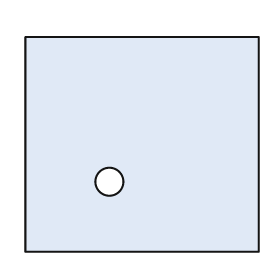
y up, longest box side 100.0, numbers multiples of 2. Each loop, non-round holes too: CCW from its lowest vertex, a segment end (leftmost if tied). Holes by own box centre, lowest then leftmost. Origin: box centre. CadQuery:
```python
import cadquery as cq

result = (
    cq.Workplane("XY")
    .moveTo(-50.0, -46.0)
    .lineTo(50.0, -46.0)
    .lineTo(50.0, 46.0)
    .lineTo(-50.0, 46.0)
    .close()
    .moveTo(-14.0, -16.0)
    .circle(6.0)
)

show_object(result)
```